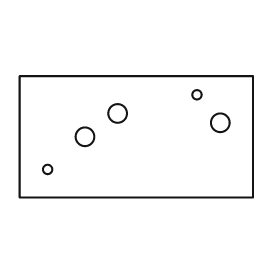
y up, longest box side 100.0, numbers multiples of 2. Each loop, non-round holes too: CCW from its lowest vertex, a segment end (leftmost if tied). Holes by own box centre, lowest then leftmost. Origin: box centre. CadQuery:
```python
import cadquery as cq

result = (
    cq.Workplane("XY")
    .moveTo(-50.0, -26.0)
    .lineTo(50.0, -26.0)
    .lineTo(50.0, 26.0)
    .lineTo(-50.0, 26.0)
    .close()
    .moveTo(-38.0, -14.0)
    .circle(2.0)
    .moveTo(-22.0, 0.0)
    .circle(4.0)
    .moveTo(36.0, 6.0)
    .circle(4.0)
    .moveTo(-8.0, 10.0)
    .circle(4.0)
    .moveTo(26.0, 18.0)
    .circle(2.0)
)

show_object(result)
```